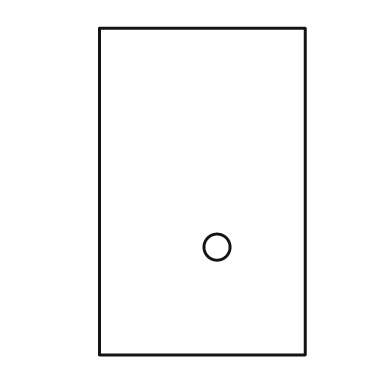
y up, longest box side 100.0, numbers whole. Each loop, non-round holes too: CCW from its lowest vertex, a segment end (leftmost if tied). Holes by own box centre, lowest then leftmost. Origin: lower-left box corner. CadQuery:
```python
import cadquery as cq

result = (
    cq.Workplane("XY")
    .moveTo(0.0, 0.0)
    .lineTo(63.0, 0.0)
    .lineTo(63.0, 100.0)
    .lineTo(0.0, 100.0)
    .close()
    .moveTo(36.0, 33.0)
    .circle(4.0)
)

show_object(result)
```